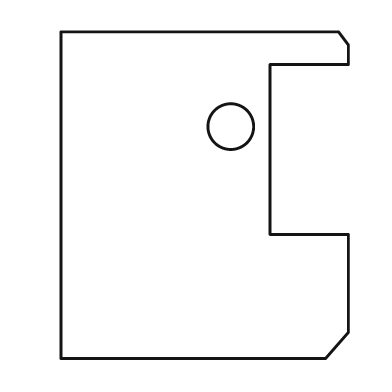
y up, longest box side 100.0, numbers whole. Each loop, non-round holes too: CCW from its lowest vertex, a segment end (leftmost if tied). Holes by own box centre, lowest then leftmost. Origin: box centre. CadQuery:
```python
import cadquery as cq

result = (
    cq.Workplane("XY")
    .moveTo(-44.0, -50.0)
    .lineTo(37.0, -50.0)
    .lineTo(44.0, -42.0)
    .lineTo(44.0, -12.0)
    .lineTo(20.0, -12.0)
    .lineTo(20.0, 40.0)
    .lineTo(44.0, 40.0)
    .lineTo(44.0, 46.0)
    .lineTo(41.0, 50.0)
    .lineTo(-44.0, 50.0)
    .close()
    .moveTo(8.0, 21.0)
    .circle(7.0)
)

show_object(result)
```